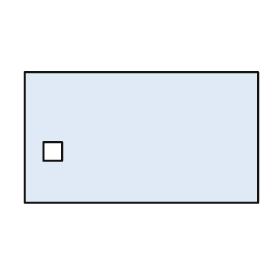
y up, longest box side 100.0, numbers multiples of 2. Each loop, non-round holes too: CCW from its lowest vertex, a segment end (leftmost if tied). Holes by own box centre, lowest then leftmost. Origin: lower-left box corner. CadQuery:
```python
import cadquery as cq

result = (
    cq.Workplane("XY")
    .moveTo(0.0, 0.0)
    .lineTo(100.0, 0.0)
    .lineTo(100.0, 56.0)
    .lineTo(0.0, 56.0)
    .close()
    .moveTo(8.0, 18.0)
    .lineTo(16.0, 18.0)
    .lineTo(16.0, 26.0)
    .lineTo(8.0, 26.0)
    .close()
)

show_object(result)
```